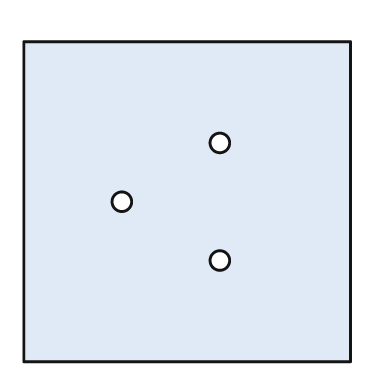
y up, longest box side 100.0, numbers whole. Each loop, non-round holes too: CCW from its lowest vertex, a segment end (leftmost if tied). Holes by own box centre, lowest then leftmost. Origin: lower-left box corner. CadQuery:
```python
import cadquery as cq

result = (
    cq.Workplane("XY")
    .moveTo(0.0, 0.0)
    .lineTo(100.0, 0.0)
    .lineTo(100.0, 98.0)
    .lineTo(0.0, 98.0)
    .close()
    .moveTo(60.0, 31.0)
    .circle(3.0)
    .moveTo(30.0, 49.0)
    .circle(3.0)
    .moveTo(60.0, 67.0)
    .circle(3.0)
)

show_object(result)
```